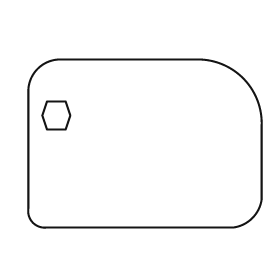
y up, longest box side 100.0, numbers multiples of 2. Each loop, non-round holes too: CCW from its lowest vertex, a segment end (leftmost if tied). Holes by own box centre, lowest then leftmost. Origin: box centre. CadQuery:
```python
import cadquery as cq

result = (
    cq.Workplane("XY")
    .moveTo(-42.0, -36.0)
    .lineTo(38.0, -36.0)
    .threePointArc((46.0, -32.0), (50.0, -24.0))
    .lineTo(50.0, 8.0)
    .threePointArc((42.0, 28.0), (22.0, 36.0))
    .lineTo(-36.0, 36.0)
    .threePointArc((-46.0, 32.0), (-50.0, 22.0))
    .lineTo(-50.0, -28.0)
    .threePointArc((-48.0, -34.0), (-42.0, -36.0))
    .close()
    .moveTo(-42.0, 6.0)
    .lineTo(-34.0, 6.0)
    .lineTo(-32.0, 12.0)
    .lineTo(-34.0, 18.0)
    .lineTo(-42.0, 18.0)
    .lineTo(-44.0, 12.0)
    .close()
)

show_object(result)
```